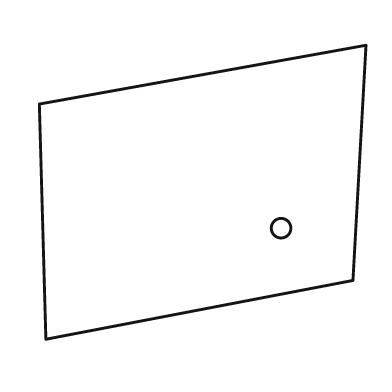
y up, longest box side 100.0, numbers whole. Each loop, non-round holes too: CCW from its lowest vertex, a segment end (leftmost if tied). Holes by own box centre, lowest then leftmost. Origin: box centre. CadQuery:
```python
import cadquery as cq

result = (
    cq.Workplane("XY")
    .moveTo(-48.0, -45.0)
    .lineTo(46.0, -27.0)
    .lineTo(50.0, 45.0)
    .lineTo(-50.0, 27.0)
    .close()
    .moveTo(24.0, -11.0)
    .circle(3.0)
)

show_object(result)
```